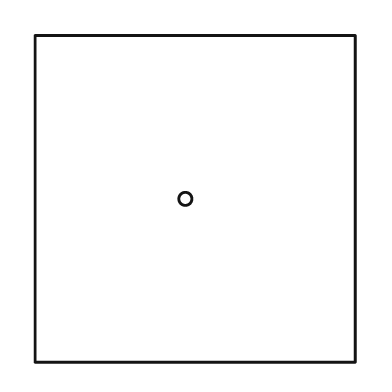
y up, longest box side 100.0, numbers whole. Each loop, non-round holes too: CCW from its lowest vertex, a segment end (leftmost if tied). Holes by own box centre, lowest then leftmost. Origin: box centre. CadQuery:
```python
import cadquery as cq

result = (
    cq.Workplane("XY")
    .moveTo(-49.0, -50.0)
    .lineTo(49.0, -50.0)
    .lineTo(49.0, 50.0)
    .lineTo(-49.0, 50.0)
    .close()
    .moveTo(-3.0, 0.0)
    .circle(2.0)
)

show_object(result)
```